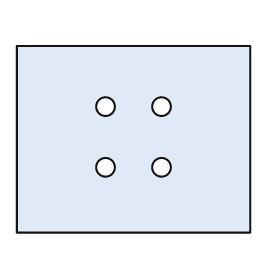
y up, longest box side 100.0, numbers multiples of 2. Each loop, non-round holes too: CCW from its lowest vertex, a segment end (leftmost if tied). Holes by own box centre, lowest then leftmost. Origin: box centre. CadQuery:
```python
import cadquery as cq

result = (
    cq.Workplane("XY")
    .moveTo(-50.0, -40.0)
    .lineTo(50.0, -40.0)
    .lineTo(50.0, 40.0)
    .lineTo(-50.0, 40.0)
    .close()
    .moveTo(-12.0, -12.0)
    .circle(4.0)
    .moveTo(12.0, -12.0)
    .circle(4.0)
    .moveTo(-12.0, 14.0)
    .circle(4.0)
    .moveTo(12.0, 14.0)
    .circle(4.0)
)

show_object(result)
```